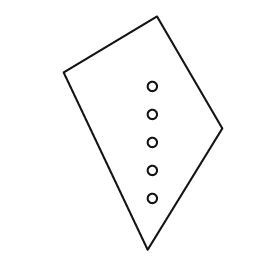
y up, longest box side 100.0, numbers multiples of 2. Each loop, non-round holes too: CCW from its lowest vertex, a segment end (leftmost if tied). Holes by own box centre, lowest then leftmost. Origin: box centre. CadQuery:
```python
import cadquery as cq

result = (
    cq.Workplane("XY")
    .moveTo(2.0, -50.0)
    .lineTo(34.0, 2.0)
    .lineTo(6.0, 50.0)
    .lineTo(-34.0, 26.0)
    .close()
    .moveTo(4.0, -28.0)
    .circle(2.0)
    .moveTo(4.0, -16.0)
    .circle(2.0)
    .moveTo(4.0, -4.0)
    .circle(2.0)
    .moveTo(4.0, 8.0)
    .circle(2.0)
    .moveTo(4.0, 20.0)
    .circle(2.0)
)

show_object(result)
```